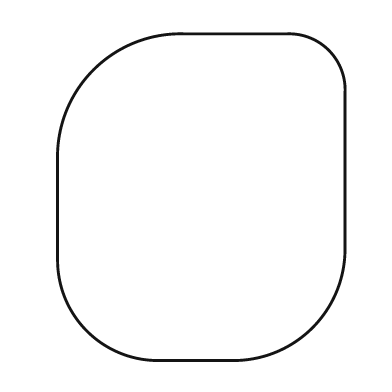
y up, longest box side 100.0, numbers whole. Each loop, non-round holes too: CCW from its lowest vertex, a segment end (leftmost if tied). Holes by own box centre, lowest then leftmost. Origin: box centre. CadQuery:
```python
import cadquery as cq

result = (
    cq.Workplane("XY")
    .moveTo(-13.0, -50.0)
    .lineTo(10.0, -50.0)
    .threePointArc((34.0, -40.0), (44.0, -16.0))
    .lineTo(44.0, 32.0)
    .threePointArc((39.0, 45.0), (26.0, 50.0))
    .lineTo(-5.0, 50.0)
    .threePointArc((-33.0, 39.0), (-44.0, 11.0))
    .lineTo(-44.0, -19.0)
    .threePointArc((-35.0, -41.0), (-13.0, -50.0))
    .close()
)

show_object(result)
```